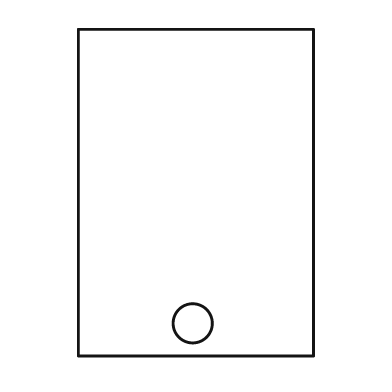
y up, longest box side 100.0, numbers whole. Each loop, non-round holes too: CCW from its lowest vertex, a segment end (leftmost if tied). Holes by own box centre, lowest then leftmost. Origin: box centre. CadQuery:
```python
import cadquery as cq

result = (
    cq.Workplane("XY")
    .moveTo(-36.0, -50.0)
    .lineTo(36.0, -50.0)
    .lineTo(36.0, 50.0)
    .lineTo(-36.0, 50.0)
    .close()
    .moveTo(-1.0, -40.0)
    .circle(6.0)
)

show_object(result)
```